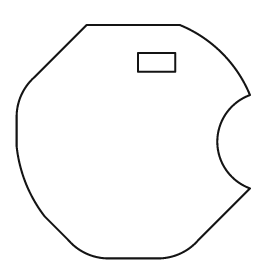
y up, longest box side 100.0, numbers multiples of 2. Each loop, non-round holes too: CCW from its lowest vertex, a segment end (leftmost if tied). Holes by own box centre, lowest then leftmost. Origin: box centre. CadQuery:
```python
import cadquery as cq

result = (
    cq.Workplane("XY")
    .moveTo(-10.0, -50.0)
    .lineTo(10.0, -50.0)
    .threePointArc((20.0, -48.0), (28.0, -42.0))
    .lineTo(50.0, -20.0)
    .threePointArc((36.0, 0.0), (50.0, 20.0))
    .threePointArc((38.0, 38.0), (20.0, 50.0))
    .lineTo(-20.0, 50.0)
    .lineTo(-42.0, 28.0)
    .threePointArc((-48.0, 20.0), (-50.0, 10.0))
    .lineTo(-50.0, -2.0)
    .threePointArc((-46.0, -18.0), (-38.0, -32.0))
    .lineTo(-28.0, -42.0)
    .threePointArc((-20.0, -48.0), (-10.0, -50.0))
    .close()
    .moveTo(2.0, 30.0)
    .lineTo(18.0, 30.0)
    .lineTo(18.0, 38.0)
    .lineTo(2.0, 38.0)
    .close()
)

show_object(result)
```